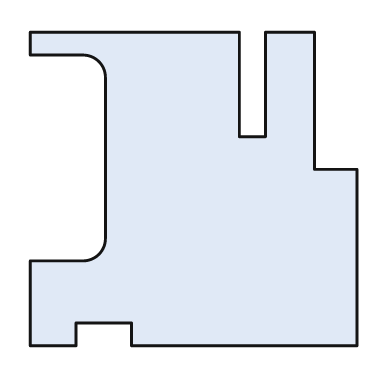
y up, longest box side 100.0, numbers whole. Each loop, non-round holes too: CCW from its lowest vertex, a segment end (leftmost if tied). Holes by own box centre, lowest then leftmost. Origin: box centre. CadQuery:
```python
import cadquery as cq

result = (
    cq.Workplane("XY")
    .moveTo(-50.0, -48.0)
    .lineTo(-36.0, -48.0)
    .lineTo(-36.0, -41.0)
    .lineTo(-19.0, -41.0)
    .lineTo(-19.0, -48.0)
    .lineTo(50.0, -48.0)
    .lineTo(50.0, 6.0)
    .lineTo(37.0, 6.0)
    .lineTo(37.0, 48.0)
    .lineTo(22.0, 48.0)
    .lineTo(22.0, 16.0)
    .lineTo(14.0, 16.0)
    .lineTo(14.0, 48.0)
    .lineTo(-50.0, 48.0)
    .lineTo(-50.0, 41.0)
    .lineTo(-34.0, 41.0)
    .threePointArc((-29.0, 39.0), (-27.0, 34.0))
    .lineTo(-27.0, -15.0)
    .threePointArc((-29.0, -20.0), (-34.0, -22.0))
    .lineTo(-50.0, -22.0)
    .close()
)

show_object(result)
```